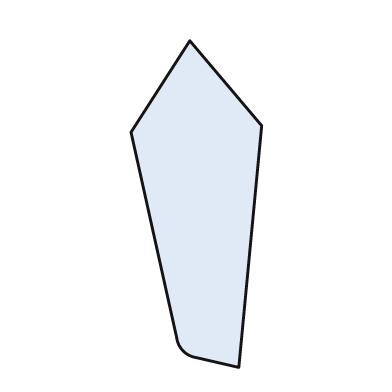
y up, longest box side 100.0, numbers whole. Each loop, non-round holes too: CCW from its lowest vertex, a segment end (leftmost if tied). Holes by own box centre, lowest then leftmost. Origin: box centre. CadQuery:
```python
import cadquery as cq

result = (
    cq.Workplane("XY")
    .moveTo(13.0, -50.0)
    .lineTo(20.0, 24.0)
    .lineTo(-2.0, 50.0)
    .lineTo(-20.0, 22.0)
    .lineTo(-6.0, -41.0)
    .threePointArc((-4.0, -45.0), (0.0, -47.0))
    .close()
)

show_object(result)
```